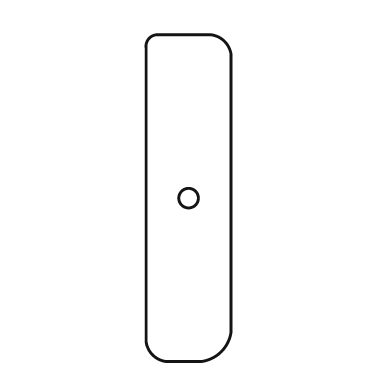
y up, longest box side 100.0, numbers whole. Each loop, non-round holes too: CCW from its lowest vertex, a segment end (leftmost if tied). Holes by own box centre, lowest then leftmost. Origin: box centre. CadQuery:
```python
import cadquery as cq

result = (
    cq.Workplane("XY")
    .moveTo(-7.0, -50.0)
    .lineTo(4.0, -50.0)
    .threePointArc((10.0, -47.0), (13.0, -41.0))
    .lineTo(13.0, 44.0)
    .threePointArc((11.0, 48.0), (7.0, 50.0))
    .lineTo(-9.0, 50.0)
    .threePointArc((-12.0, 49.0), (-13.0, 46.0))
    .lineTo(-13.0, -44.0)
    .threePointArc((-11.0, -48.0), (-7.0, -50.0))
    .close()
    .moveTo(0.0, 0.0)
    .circle(3.0)
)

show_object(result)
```